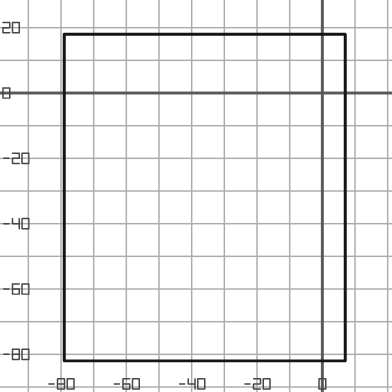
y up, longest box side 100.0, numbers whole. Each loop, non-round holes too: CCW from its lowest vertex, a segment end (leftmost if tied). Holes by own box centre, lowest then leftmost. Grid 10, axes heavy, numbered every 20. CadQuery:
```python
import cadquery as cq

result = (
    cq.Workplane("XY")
    .moveTo(-79.0, -82.0)
    .lineTo(7.0, -82.0)
    .lineTo(7.0, 18.0)
    .lineTo(-79.0, 18.0)
    .close()
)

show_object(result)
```